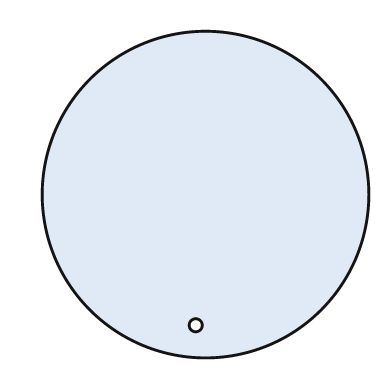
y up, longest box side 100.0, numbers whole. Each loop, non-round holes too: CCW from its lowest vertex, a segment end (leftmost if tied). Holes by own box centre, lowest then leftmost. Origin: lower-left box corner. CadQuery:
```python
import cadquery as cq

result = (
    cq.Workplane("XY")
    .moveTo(50.0, 50.0)
    .circle(50.0)
    .moveTo(47.0, 10.0)
    .circle(2.0)
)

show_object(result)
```